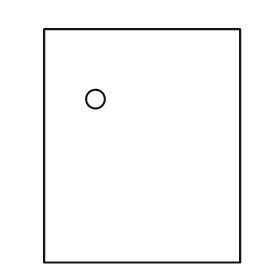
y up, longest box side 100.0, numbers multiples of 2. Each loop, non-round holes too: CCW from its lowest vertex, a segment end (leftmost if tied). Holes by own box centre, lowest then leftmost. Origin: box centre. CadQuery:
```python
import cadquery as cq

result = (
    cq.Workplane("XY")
    .moveTo(-42.0, -50.0)
    .lineTo(42.0, -50.0)
    .lineTo(42.0, 50.0)
    .lineTo(-42.0, 50.0)
    .close()
    .moveTo(-20.0, 20.0)
    .circle(4.0)
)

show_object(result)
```